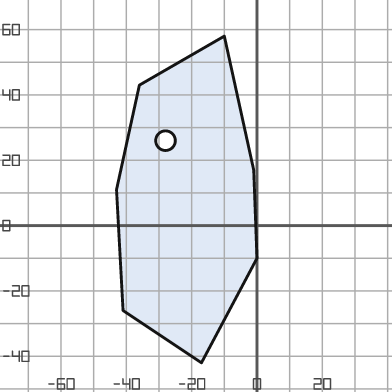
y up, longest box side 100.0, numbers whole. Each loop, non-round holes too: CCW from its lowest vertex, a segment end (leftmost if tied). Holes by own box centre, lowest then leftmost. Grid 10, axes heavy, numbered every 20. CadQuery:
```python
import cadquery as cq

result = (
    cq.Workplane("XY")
    .moveTo(-17.0, -42.0)
    .lineTo(0.0, -10.0)
    .lineTo(-1.0, 17.0)
    .lineTo(-10.0, 58.0)
    .lineTo(-36.0, 43.0)
    .lineTo(-43.0, 11.0)
    .lineTo(-41.0, -26.0)
    .close()
    .moveTo(-28.0, 26.0)
    .circle(3.0)
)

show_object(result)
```